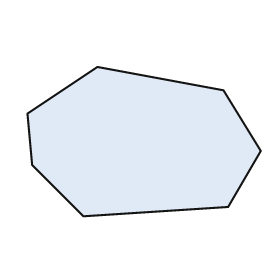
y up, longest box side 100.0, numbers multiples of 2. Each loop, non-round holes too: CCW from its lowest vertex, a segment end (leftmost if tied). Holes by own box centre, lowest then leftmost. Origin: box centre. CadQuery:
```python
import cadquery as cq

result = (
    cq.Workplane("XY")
    .moveTo(-26.0, -32.0)
    .lineTo(36.0, -28.0)
    .lineTo(50.0, -4.0)
    .lineTo(34.0, 22.0)
    .lineTo(-20.0, 32.0)
    .lineTo(-50.0, 12.0)
    .lineTo(-48.0, -10.0)
    .close()
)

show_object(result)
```